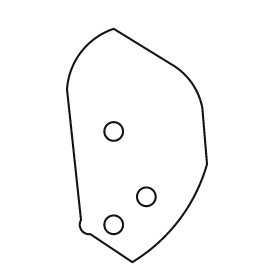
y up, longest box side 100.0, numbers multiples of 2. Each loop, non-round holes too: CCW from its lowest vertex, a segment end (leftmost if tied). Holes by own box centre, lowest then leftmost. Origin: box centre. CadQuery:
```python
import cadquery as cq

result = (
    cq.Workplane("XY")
    .moveTo(-2.0, -50.0)
    .threePointArc((18.0, -32.0), (30.0, -8.0))
    .lineTo(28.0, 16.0)
    .threePointArc((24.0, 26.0), (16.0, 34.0))
    .lineTo(-10.0, 50.0)
    .threePointArc((-24.0, 40.0), (-30.0, 24.0))
    .lineTo(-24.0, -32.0)
    .threePointArc((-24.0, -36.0), (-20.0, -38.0))
    .close()
    .moveTo(-10.0, -34.0)
    .circle(4.0)
    .moveTo(4.0, -22.0)
    .circle(4.0)
    .moveTo(-10.0, 6.0)
    .circle(4.0)
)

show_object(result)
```